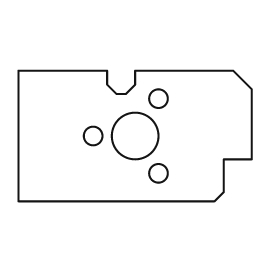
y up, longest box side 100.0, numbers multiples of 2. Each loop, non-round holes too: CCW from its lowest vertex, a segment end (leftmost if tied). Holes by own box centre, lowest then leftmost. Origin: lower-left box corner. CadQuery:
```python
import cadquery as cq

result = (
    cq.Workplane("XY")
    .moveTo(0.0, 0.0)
    .lineTo(84.0, 0.0)
    .lineTo(88.0, 4.0)
    .lineTo(88.0, 18.0)
    .lineTo(100.0, 18.0)
    .lineTo(100.0, 48.0)
    .lineTo(92.0, 56.0)
    .lineTo(50.0, 56.0)
    .lineTo(50.0, 50.0)
    .lineTo(46.0, 46.0)
    .lineTo(42.0, 46.0)
    .lineTo(38.0, 50.0)
    .lineTo(38.0, 56.0)
    .lineTo(0.0, 56.0)
    .close()
    .moveTo(60.0, 12.0)
    .circle(4.0)
    .moveTo(32.0, 28.0)
    .circle(4.0)
    .moveTo(50.0, 28.0)
    .circle(10.0)
    .moveTo(60.0, 44.0)
    .circle(4.0)
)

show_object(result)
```